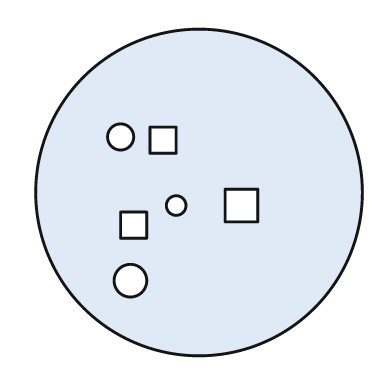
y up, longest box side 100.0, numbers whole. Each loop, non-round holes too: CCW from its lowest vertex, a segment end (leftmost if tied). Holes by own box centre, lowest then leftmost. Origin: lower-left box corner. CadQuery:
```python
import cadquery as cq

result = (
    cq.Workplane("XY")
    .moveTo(50.0, 50.0)
    .circle(50.0)
    .moveTo(29.0, 23.0)
    .circle(5.0)
    .moveTo(26.0, 36.0)
    .lineTo(34.0, 36.0)
    .lineTo(34.0, 44.0)
    .lineTo(26.0, 44.0)
    .close()
    .moveTo(43.0, 46.0)
    .circle(3.0)
    .moveTo(58.0, 41.0)
    .lineTo(68.0, 41.0)
    .lineTo(68.0, 51.0)
    .lineTo(58.0, 51.0)
    .close()
    .moveTo(35.0, 62.0)
    .lineTo(43.0, 62.0)
    .lineTo(43.0, 70.0)
    .lineTo(35.0, 70.0)
    .close()
    .moveTo(26.0, 67.0)
    .circle(4.0)
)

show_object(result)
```